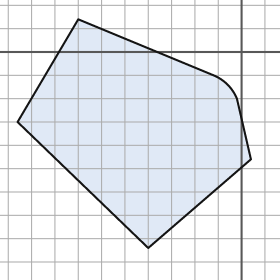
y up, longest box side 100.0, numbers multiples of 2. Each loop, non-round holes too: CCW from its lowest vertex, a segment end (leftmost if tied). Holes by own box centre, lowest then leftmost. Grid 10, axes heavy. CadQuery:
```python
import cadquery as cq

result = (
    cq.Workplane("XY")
    .moveTo(-40.0, -84.0)
    .lineTo(4.0, -46.0)
    .lineTo(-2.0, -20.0)
    .threePointArc((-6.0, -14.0), (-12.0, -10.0))
    .lineTo(-70.0, 14.0)
    .lineTo(-96.0, -30.0)
    .close()
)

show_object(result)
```